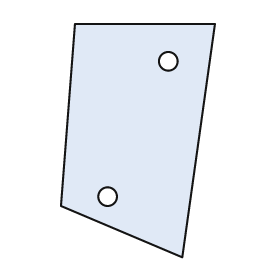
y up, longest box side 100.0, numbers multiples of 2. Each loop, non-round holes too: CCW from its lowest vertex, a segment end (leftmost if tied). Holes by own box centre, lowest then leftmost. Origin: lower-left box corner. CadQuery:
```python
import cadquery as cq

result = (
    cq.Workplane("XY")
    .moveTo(52.0, 0.0)
    .lineTo(66.0, 100.0)
    .lineTo(6.0, 100.0)
    .lineTo(0.0, 22.0)
    .close()
    .moveTo(20.0, 26.0)
    .circle(4.0)
    .moveTo(46.0, 84.0)
    .circle(4.0)
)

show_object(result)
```